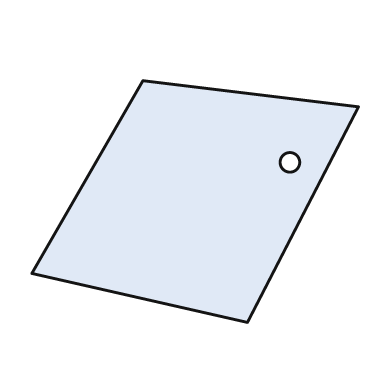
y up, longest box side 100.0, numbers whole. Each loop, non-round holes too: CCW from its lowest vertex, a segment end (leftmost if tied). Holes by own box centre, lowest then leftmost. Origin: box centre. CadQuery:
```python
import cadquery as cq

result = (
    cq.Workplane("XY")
    .moveTo(16.0, -37.0)
    .lineTo(50.0, 29.0)
    .lineTo(-16.0, 37.0)
    .lineTo(-50.0, -22.0)
    .close()
    .moveTo(29.0, 12.0)
    .circle(3.0)
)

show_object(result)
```